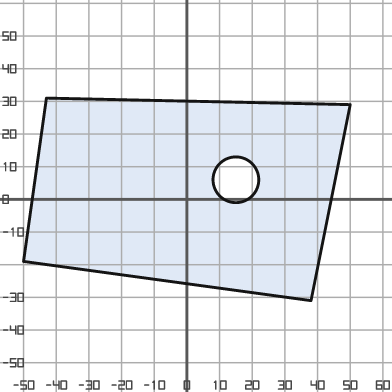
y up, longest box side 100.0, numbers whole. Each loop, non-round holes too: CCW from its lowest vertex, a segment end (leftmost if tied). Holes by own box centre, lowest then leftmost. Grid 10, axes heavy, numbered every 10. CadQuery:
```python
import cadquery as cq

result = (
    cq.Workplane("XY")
    .moveTo(38.0, -31.0)
    .lineTo(50.0, 29.0)
    .lineTo(-43.0, 31.0)
    .lineTo(-50.0, -19.0)
    .close()
    .moveTo(15.0, 6.0)
    .circle(7.0)
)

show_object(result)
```